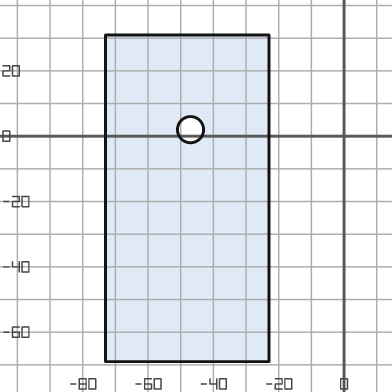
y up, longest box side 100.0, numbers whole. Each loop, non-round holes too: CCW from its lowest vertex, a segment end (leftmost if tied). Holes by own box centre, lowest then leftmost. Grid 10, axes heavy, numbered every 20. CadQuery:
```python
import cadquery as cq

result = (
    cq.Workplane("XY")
    .moveTo(-73.0, -69.0)
    .lineTo(-23.0, -69.0)
    .lineTo(-23.0, 31.0)
    .lineTo(-73.0, 31.0)
    .close()
    .moveTo(-47.0, 2.0)
    .circle(4.0)
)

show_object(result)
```